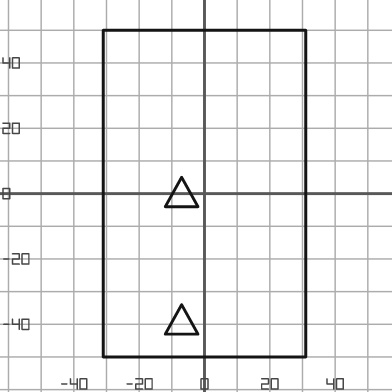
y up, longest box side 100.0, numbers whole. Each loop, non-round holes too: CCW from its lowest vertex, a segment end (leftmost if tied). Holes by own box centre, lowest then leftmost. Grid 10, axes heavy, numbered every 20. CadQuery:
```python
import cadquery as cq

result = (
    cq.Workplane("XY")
    .moveTo(-31.0, -50.0)
    .lineTo(31.0, -50.0)
    .lineTo(31.0, 50.0)
    .lineTo(-31.0, 50.0)
    .close()
    .moveTo(-12.0, -43.0)
    .lineTo(-2.0, -43.0)
    .lineTo(-7.0, -34.0)
    .close()
    .moveTo(-12.0, -4.0)
    .lineTo(-2.0, -4.0)
    .lineTo(-7.0, 5.0)
    .close()
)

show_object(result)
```